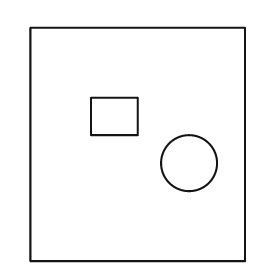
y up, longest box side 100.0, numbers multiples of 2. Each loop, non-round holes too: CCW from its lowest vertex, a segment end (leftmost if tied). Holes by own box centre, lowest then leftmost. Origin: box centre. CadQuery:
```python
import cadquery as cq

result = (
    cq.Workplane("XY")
    .moveTo(-46.0, -50.0)
    .lineTo(46.0, -50.0)
    .lineTo(46.0, 50.0)
    .lineTo(-46.0, 50.0)
    .close()
    .moveTo(22.0, -8.0)
    .circle(12.0)
    .moveTo(-20.0, 4.0)
    .lineTo(0.0, 4.0)
    .lineTo(0.0, 20.0)
    .lineTo(-20.0, 20.0)
    .close()
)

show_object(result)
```